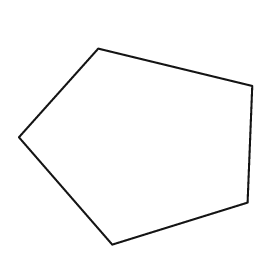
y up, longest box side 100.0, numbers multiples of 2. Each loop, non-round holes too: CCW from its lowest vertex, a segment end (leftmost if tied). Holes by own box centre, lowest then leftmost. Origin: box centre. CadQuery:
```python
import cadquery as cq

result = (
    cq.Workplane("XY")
    .moveTo(-10.0, -42.0)
    .lineTo(48.0, -24.0)
    .lineTo(50.0, 26.0)
    .lineTo(-16.0, 42.0)
    .lineTo(-50.0, 4.0)
    .close()
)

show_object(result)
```